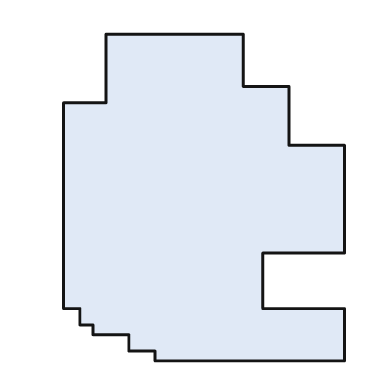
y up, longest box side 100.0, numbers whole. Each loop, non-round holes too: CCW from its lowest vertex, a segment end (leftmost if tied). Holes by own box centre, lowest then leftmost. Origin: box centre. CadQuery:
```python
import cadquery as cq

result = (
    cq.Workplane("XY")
    .moveTo(-15.0, -50.0)
    .lineTo(43.0, -50.0)
    .lineTo(43.0, -34.0)
    .lineTo(18.0, -34.0)
    .lineTo(18.0, -17.0)
    .lineTo(43.0, -17.0)
    .lineTo(43.0, 16.0)
    .lineTo(26.0, 16.0)
    .lineTo(26.0, 34.0)
    .lineTo(12.0, 34.0)
    .lineTo(12.0, 50.0)
    .lineTo(-30.0, 50.0)
    .lineTo(-30.0, 29.0)
    .lineTo(-43.0, 29.0)
    .lineTo(-43.0, -34.0)
    .lineTo(-38.0, -34.0)
    .lineTo(-38.0, -39.0)
    .lineTo(-34.0, -39.0)
    .lineTo(-34.0, -42.0)
    .lineTo(-23.0, -42.0)
    .lineTo(-23.0, -47.0)
    .lineTo(-15.0, -47.0)
    .close()
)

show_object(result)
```